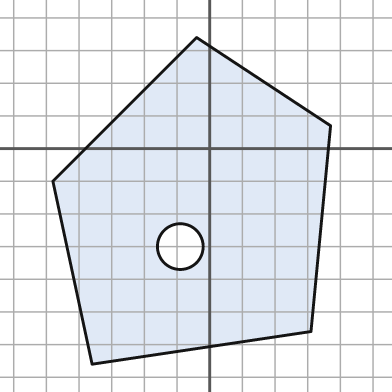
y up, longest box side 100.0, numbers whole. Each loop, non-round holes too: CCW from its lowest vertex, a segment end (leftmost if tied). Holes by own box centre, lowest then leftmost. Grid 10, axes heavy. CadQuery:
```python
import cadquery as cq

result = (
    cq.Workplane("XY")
    .moveTo(-36.0, -66.0)
    .lineTo(31.0, -56.0)
    .lineTo(37.0, 7.0)
    .lineTo(-4.0, 34.0)
    .lineTo(-48.0, -10.0)
    .close()
    .moveTo(-9.0, -30.0)
    .circle(7.0)
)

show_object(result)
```